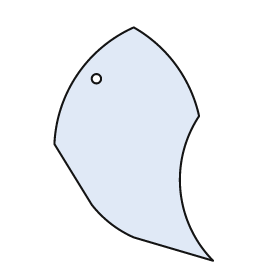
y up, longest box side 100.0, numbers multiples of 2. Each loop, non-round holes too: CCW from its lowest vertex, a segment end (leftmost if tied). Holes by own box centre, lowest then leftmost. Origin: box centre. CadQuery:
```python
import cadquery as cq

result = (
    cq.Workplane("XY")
    .moveTo(34.0, -50.0)
    .threePointArc((20.0, -20.0), (28.0, 12.0))
    .threePointArc((18.0, 34.0), (0.0, 50.0))
    .threePointArc((-24.0, 30.0), (-34.0, 0.0))
    .lineTo(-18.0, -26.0)
    .threePointArc((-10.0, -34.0), (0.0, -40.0))
    .close()
    .moveTo(-16.0, 28.0)
    .circle(2.0)
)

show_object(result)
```